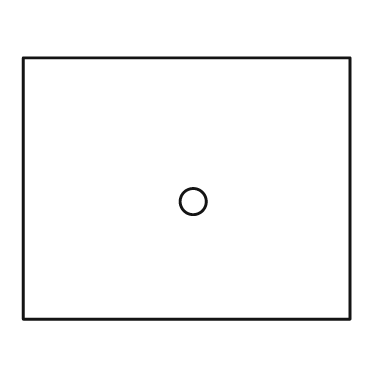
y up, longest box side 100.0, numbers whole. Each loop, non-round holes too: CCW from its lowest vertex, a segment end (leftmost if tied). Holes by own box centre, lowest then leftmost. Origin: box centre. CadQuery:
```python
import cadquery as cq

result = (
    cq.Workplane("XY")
    .moveTo(-50.0, -40.0)
    .lineTo(50.0, -40.0)
    .lineTo(50.0, 40.0)
    .lineTo(-50.0, 40.0)
    .close()
    .moveTo(2.0, -4.0)
    .circle(4.0)
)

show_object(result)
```